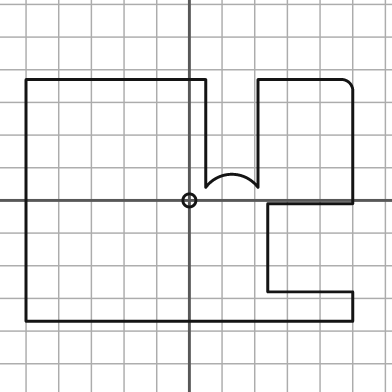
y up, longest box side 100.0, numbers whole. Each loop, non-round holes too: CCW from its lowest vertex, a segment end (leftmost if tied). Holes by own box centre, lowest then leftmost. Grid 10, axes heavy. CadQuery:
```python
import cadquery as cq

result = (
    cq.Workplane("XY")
    .moveTo(-50.0, -37.0)
    .lineTo(50.0, -37.0)
    .lineTo(50.0, -28.0)
    .lineTo(24.0, -28.0)
    .lineTo(24.0, -1.0)
    .lineTo(50.0, -1.0)
    .lineTo(50.0, 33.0)
    .threePointArc((49.0, 36.0), (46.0, 37.0))
    .lineTo(21.0, 37.0)
    .lineTo(21.0, 4.0)
    .threePointArc((13.0, 8.0), (5.0, 4.0))
    .lineTo(5.0, 37.0)
    .lineTo(-50.0, 37.0)
    .close()
    .moveTo(0.0, 0.0)
    .circle(2.0)
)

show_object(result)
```